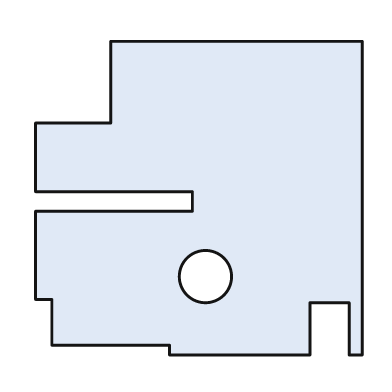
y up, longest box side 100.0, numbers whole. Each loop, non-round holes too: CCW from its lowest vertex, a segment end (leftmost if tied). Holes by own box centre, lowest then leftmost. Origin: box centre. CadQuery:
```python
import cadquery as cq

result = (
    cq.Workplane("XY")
    .moveTo(-9.0, -48.0)
    .lineTo(34.0, -48.0)
    .lineTo(34.0, -32.0)
    .lineTo(46.0, -32.0)
    .lineTo(46.0, -48.0)
    .lineTo(50.0, -48.0)
    .lineTo(50.0, 48.0)
    .lineTo(-27.0, 48.0)
    .lineTo(-27.0, 23.0)
    .lineTo(-50.0, 23.0)
    .lineTo(-50.0, 2.0)
    .lineTo(-2.0, 2.0)
    .lineTo(-2.0, -4.0)
    .lineTo(-50.0, -4.0)
    .lineTo(-50.0, -31.0)
    .lineTo(-45.0, -31.0)
    .lineTo(-45.0, -45.0)
    .lineTo(-9.0, -45.0)
    .close()
    .moveTo(2.0, -24.0)
    .circle(8.0)
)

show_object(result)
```